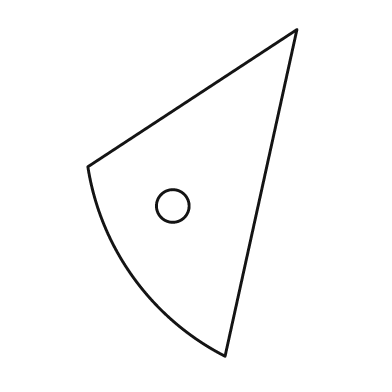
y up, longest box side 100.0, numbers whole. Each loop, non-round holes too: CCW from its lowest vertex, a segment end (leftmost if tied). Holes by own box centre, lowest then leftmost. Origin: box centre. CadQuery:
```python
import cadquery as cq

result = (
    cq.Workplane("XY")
    .moveTo(10.0, -50.0)
    .lineTo(32.0, 50.0)
    .lineTo(-32.0, 8.0)
    .threePointArc((-18.0, -26.0), (10.0, -50.0))
    .close()
    .moveTo(-6.0, -4.0)
    .circle(5.0)
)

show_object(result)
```